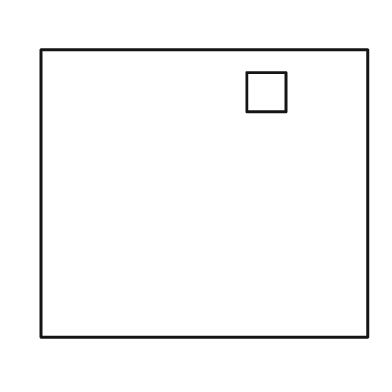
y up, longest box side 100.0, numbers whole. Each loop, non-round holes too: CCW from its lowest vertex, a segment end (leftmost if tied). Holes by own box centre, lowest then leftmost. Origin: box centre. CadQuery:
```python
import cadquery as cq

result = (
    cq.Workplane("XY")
    .moveTo(-50.0, -44.0)
    .lineTo(50.0, -44.0)
    .lineTo(50.0, 44.0)
    .lineTo(-50.0, 44.0)
    .close()
    .moveTo(13.0, 25.0)
    .lineTo(25.0, 25.0)
    .lineTo(25.0, 37.0)
    .lineTo(13.0, 37.0)
    .close()
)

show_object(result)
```